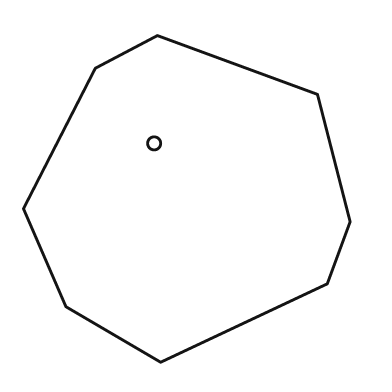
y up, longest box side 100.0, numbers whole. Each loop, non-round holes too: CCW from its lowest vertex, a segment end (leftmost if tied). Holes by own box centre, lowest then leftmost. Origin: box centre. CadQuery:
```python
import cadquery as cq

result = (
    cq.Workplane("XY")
    .moveTo(-8.0, -50.0)
    .lineTo(43.0, -26.0)
    .lineTo(50.0, -7.0)
    .lineTo(40.0, 32.0)
    .lineTo(-9.0, 50.0)
    .lineTo(-28.0, 40.0)
    .lineTo(-50.0, -3.0)
    .lineTo(-37.0, -33.0)
    .close()
    .moveTo(-10.0, 17.0)
    .circle(2.0)
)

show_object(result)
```